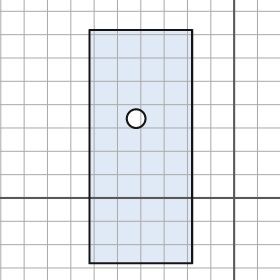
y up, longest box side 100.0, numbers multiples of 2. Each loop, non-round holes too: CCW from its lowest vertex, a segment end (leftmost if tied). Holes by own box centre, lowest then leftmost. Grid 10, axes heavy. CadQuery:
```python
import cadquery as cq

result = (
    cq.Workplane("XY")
    .moveTo(-62.0, -28.0)
    .lineTo(-18.0, -28.0)
    .lineTo(-18.0, 72.0)
    .lineTo(-62.0, 72.0)
    .close()
    .moveTo(-42.0, 34.0)
    .circle(4.0)
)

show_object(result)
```